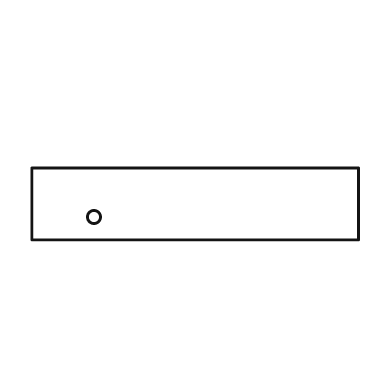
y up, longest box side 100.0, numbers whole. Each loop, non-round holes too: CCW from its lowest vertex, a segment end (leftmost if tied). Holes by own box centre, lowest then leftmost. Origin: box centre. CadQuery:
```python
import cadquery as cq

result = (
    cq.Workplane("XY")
    .moveTo(-50.0, -11.0)
    .lineTo(50.0, -11.0)
    .lineTo(50.0, 11.0)
    .lineTo(-50.0, 11.0)
    .close()
    .moveTo(-31.0, -4.0)
    .circle(2.0)
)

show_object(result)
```